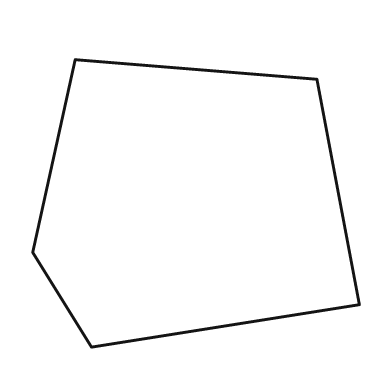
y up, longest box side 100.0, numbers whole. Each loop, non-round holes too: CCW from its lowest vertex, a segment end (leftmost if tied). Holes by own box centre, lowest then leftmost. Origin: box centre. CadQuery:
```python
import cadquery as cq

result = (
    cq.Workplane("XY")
    .moveTo(-32.0, -44.0)
    .lineTo(50.0, -31.0)
    .lineTo(37.0, 38.0)
    .lineTo(-37.0, 44.0)
    .lineTo(-50.0, -15.0)
    .close()
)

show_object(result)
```